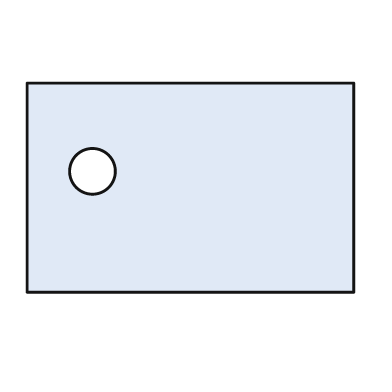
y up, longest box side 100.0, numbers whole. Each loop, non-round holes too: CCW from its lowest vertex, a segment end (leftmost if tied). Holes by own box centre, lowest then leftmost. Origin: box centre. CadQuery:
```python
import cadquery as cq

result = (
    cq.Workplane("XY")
    .moveTo(-50.0, -32.0)
    .lineTo(50.0, -32.0)
    .lineTo(50.0, 32.0)
    .lineTo(-50.0, 32.0)
    .close()
    .moveTo(-30.0, 5.0)
    .circle(7.0)
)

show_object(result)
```